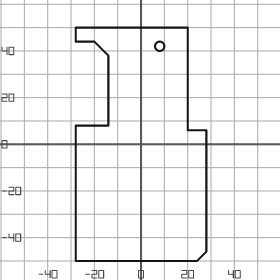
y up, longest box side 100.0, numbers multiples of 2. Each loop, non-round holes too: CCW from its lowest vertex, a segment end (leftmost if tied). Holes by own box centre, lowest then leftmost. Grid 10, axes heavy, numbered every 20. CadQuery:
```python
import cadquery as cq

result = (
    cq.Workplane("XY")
    .moveTo(-28.0, -50.0)
    .lineTo(24.0, -50.0)
    .lineTo(28.0, -46.0)
    .lineTo(28.0, 6.0)
    .lineTo(20.0, 6.0)
    .lineTo(20.0, 50.0)
    .lineTo(-28.0, 50.0)
    .lineTo(-28.0, 44.0)
    .lineTo(-20.0, 44.0)
    .lineTo(-14.0, 38.0)
    .lineTo(-14.0, 8.0)
    .lineTo(-28.0, 8.0)
    .close()
    .moveTo(8.0, 42.0)
    .circle(2.0)
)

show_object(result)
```